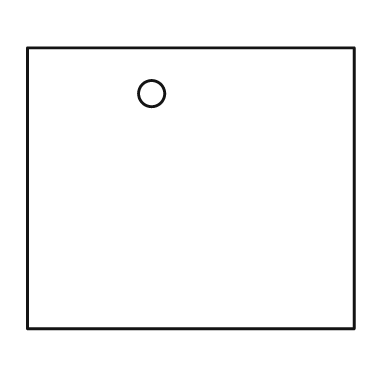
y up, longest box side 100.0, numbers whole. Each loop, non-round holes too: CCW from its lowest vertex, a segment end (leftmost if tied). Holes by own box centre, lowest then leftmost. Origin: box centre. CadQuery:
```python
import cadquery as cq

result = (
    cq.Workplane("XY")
    .moveTo(-50.0, -43.0)
    .lineTo(50.0, -43.0)
    .lineTo(50.0, 43.0)
    .lineTo(-50.0, 43.0)
    .close()
    .moveTo(-12.0, 29.0)
    .circle(4.0)
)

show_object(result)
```